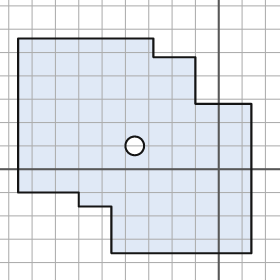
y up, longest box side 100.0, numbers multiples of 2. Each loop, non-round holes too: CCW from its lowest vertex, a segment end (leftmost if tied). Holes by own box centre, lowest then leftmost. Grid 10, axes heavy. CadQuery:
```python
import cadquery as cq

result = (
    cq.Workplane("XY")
    .moveTo(-46.0, -36.0)
    .lineTo(14.0, -36.0)
    .lineTo(14.0, 28.0)
    .lineTo(-10.0, 28.0)
    .lineTo(-10.0, 48.0)
    .lineTo(-28.0, 48.0)
    .lineTo(-28.0, 56.0)
    .lineTo(-86.0, 56.0)
    .lineTo(-86.0, -10.0)
    .lineTo(-60.0, -10.0)
    .lineTo(-60.0, -16.0)
    .lineTo(-46.0, -16.0)
    .close()
    .moveTo(-36.0, 10.0)
    .circle(4.0)
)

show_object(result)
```